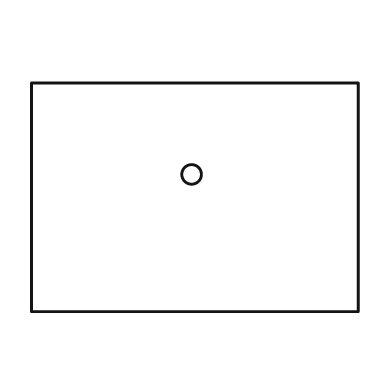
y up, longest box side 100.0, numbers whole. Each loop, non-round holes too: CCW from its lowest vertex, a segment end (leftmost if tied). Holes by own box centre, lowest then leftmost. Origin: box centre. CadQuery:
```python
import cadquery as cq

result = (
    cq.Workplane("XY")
    .moveTo(-50.0, -35.0)
    .lineTo(50.0, -35.0)
    .lineTo(50.0, 35.0)
    .lineTo(-50.0, 35.0)
    .close()
    .moveTo(-1.0, 7.0)
    .circle(3.0)
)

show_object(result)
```